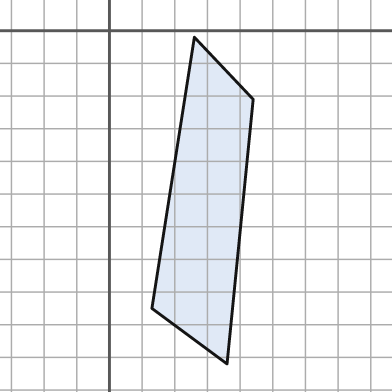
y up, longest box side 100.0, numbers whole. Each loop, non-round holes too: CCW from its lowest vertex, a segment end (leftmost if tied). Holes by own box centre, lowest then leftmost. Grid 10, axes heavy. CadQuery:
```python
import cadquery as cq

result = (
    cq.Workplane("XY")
    .moveTo(36.0, -102.0)
    .lineTo(44.0, -21.0)
    .lineTo(26.0, -2.0)
    .lineTo(13.0, -85.0)
    .close()
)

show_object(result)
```